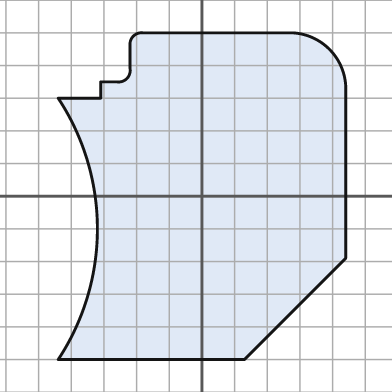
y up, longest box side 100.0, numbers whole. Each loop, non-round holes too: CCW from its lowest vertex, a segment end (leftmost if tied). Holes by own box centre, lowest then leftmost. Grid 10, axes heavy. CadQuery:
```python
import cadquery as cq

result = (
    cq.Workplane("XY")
    .moveTo(-44.0, -50.0)
    .lineTo(13.0, -50.0)
    .lineTo(44.0, -19.0)
    .lineTo(44.0, 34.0)
    .threePointArc((39.0, 45.0), (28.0, 50.0))
    .lineTo(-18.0, 50.0)
    .threePointArc((-21.0, 49.0), (-22.0, 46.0))
    .lineTo(-22.0, 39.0)
    .threePointArc((-23.0, 36.0), (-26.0, 35.0))
    .lineTo(-31.0, 35.0)
    .lineTo(-31.0, 30.0)
    .lineTo(-44.0, 30.0)
    .threePointArc((-32.0, -10.0), (-44.0, -50.0))
    .close()
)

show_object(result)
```